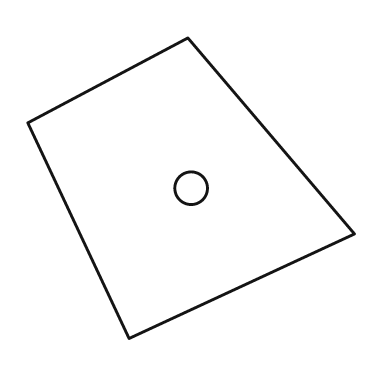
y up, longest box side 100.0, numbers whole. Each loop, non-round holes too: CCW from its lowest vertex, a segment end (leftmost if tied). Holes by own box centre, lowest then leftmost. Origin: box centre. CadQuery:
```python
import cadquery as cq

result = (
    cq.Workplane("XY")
    .moveTo(-19.0, -46.0)
    .lineTo(50.0, -14.0)
    .lineTo(-1.0, 46.0)
    .lineTo(-50.0, 20.0)
    .close()
    .moveTo(0.0, 0.0)
    .circle(5.0)
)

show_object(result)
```